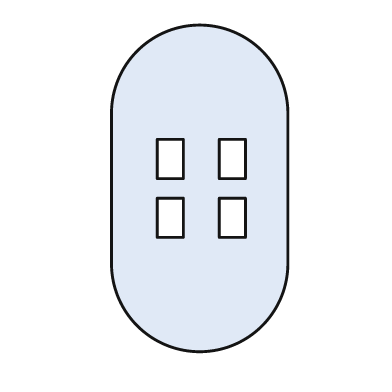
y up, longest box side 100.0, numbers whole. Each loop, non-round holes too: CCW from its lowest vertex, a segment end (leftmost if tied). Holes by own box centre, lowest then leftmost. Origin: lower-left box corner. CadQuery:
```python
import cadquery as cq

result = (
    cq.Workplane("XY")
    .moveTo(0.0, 27.0)
    .threePointArc((27.0, 0.0), (54.0, 27.0))
    .lineTo(54.0, 73.0)
    .threePointArc((27.0, 100.0), (0.0, 73.0))
    .close()
    .moveTo(14.0, 35.0)
    .lineTo(22.0, 35.0)
    .lineTo(22.0, 47.0)
    .lineTo(14.0, 47.0)
    .close()
    .moveTo(33.0, 35.0)
    .lineTo(41.0, 35.0)
    .lineTo(41.0, 47.0)
    .lineTo(33.0, 47.0)
    .close()
    .moveTo(14.0, 53.0)
    .lineTo(22.0, 53.0)
    .lineTo(22.0, 65.0)
    .lineTo(14.0, 65.0)
    .close()
    .moveTo(33.0, 53.0)
    .lineTo(41.0, 53.0)
    .lineTo(41.0, 65.0)
    .lineTo(33.0, 65.0)
    .close()
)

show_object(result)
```